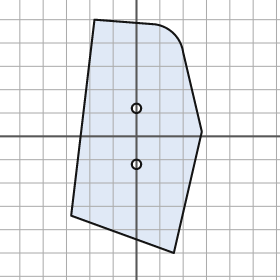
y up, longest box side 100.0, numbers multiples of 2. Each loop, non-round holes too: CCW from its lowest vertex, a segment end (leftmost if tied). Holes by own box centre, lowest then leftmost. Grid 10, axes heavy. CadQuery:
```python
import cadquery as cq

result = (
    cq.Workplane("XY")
    .moveTo(16.0, -50.0)
    .lineTo(28.0, 2.0)
    .lineTo(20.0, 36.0)
    .threePointArc((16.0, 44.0), (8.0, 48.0))
    .lineTo(-18.0, 50.0)
    .lineTo(-28.0, -34.0)
    .close()
    .moveTo(0.0, -12.0)
    .circle(2.0)
    .moveTo(0.0, 12.0)
    .circle(2.0)
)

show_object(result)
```